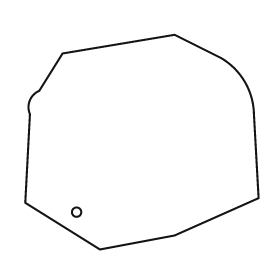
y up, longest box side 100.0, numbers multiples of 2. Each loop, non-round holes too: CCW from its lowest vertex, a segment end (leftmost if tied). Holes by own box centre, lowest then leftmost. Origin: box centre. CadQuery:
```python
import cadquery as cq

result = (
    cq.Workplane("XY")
    .moveTo(-18.0, -46.0)
    .lineTo(14.0, -40.0)
    .lineTo(50.0, -24.0)
    .lineTo(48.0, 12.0)
    .threePointArc((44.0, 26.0), (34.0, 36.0))
    .lineTo(14.0, 46.0)
    .lineTo(-34.0, 38.0)
    .lineTo(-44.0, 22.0)
    .threePointArc((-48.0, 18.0), (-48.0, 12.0))
    .lineTo(-50.0, -26.0)
    .close()
    .moveTo(-28.0, -30.0)
    .circle(2.0)
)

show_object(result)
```